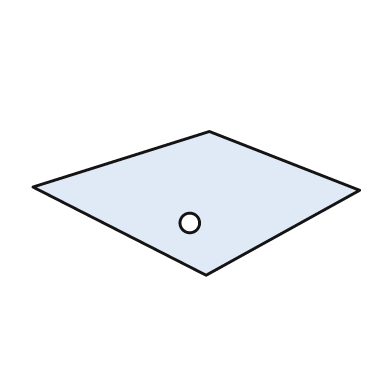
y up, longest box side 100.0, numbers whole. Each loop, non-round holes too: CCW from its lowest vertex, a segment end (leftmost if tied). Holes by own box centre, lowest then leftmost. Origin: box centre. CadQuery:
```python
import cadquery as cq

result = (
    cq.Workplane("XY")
    .moveTo(3.0, -22.0)
    .lineTo(50.0, 4.0)
    .lineTo(4.0, 22.0)
    .lineTo(-50.0, 5.0)
    .close()
    .moveTo(-2.0, -6.0)
    .circle(3.0)
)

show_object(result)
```